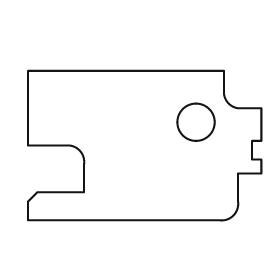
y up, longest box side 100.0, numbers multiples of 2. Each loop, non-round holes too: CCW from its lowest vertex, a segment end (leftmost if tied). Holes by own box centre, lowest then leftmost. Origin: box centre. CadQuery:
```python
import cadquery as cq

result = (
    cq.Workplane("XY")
    .moveTo(-50.0, -32.0)
    .lineTo(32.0, -32.0)
    .threePointArc((38.0, -30.0), (40.0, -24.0))
    .lineTo(40.0, -12.0)
    .lineTo(50.0, -12.0)
    .lineTo(50.0, -6.0)
    .lineTo(46.0, -6.0)
    .lineTo(46.0, 2.0)
    .lineTo(50.0, 2.0)
    .lineTo(50.0, 16.0)
    .lineTo(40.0, 16.0)
    .threePointArc((36.0, 18.0), (34.0, 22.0))
    .lineTo(34.0, 32.0)
    .lineTo(-50.0, 32.0)
    .lineTo(-50.0, 0.0)
    .lineTo(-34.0, 0.0)
    .threePointArc((-28.0, -2.0), (-26.0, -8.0))
    .lineTo(-26.0, -20.0)
    .lineTo(-46.0, -20.0)
    .lineTo(-50.0, -24.0)
    .close()
    .moveTo(22.0, 10.0)
    .circle(8.0)
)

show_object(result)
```